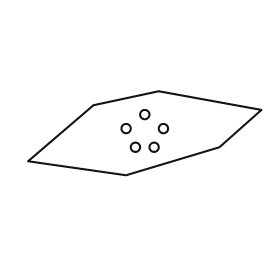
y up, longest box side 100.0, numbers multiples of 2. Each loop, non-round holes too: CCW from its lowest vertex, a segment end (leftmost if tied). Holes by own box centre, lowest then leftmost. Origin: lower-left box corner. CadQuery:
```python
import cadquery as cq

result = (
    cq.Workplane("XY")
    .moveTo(42.0, 0.0)
    .lineTo(82.0, 12.0)
    .lineTo(100.0, 28.0)
    .lineTo(56.0, 36.0)
    .lineTo(28.0, 30.0)
    .lineTo(0.0, 6.0)
    .close()
    .moveTo(46.0, 12.0)
    .circle(2.0)
    .moveTo(54.0, 12.0)
    .circle(2.0)
    .moveTo(42.0, 20.0)
    .circle(2.0)
    .moveTo(58.0, 20.0)
    .circle(2.0)
    .moveTo(50.0, 26.0)
    .circle(2.0)
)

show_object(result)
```